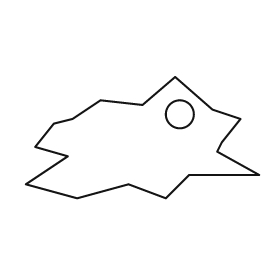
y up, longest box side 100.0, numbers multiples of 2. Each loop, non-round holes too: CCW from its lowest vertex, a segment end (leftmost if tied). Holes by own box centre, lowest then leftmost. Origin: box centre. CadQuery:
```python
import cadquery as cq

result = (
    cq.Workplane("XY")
    .moveTo(-28.0, -26.0)
    .lineTo(-6.0, -20.0)
    .lineTo(10.0, -26.0)
    .lineTo(20.0, -16.0)
    .lineTo(50.0, -16.0)
    .lineTo(32.0, -6.0)
    .lineTo(34.0, -2.0)
    .lineTo(42.0, 8.0)
    .lineTo(30.0, 12.0)
    .lineTo(14.0, 26.0)
    .lineTo(0.0, 14.0)
    .lineTo(-18.0, 16.0)
    .lineTo(-30.0, 8.0)
    .lineTo(-38.0, 6.0)
    .lineTo(-46.0, -4.0)
    .lineTo(-32.0, -8.0)
    .lineTo(-50.0, -20.0)
    .close()
    .moveTo(16.0, 10.0)
    .circle(6.0)
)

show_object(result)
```